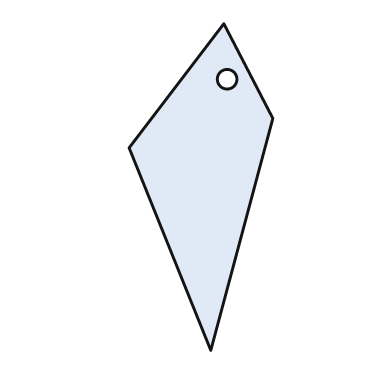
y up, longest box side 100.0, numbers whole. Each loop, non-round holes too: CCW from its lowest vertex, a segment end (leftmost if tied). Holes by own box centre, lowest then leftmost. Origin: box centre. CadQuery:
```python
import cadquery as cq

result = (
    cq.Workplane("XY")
    .moveTo(3.0, -50.0)
    .lineTo(22.0, 21.0)
    .lineTo(7.0, 50.0)
    .lineTo(-22.0, 12.0)
    .close()
    .moveTo(8.0, 33.0)
    .circle(3.0)
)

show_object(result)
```